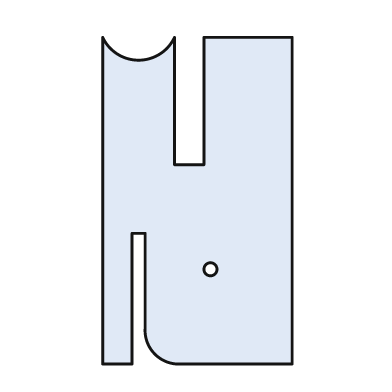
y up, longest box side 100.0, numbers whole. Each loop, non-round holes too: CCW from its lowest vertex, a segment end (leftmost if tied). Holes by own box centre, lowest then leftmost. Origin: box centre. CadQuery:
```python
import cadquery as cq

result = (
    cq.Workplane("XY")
    .moveTo(-29.0, -50.0)
    .lineTo(-20.0, -50.0)
    .lineTo(-20.0, -10.0)
    .lineTo(-16.0, -10.0)
    .lineTo(-16.0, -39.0)
    .threePointArc((-13.0, -47.0), (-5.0, -50.0))
    .lineTo(29.0, -50.0)
    .lineTo(29.0, 50.0)
    .lineTo(2.0, 50.0)
    .lineTo(2.0, 11.0)
    .lineTo(-7.0, 11.0)
    .lineTo(-7.0, 50.0)
    .threePointArc((-18.0, 43.0), (-29.0, 50.0))
    .close()
    .moveTo(4.0, -21.0)
    .circle(2.0)
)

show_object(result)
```